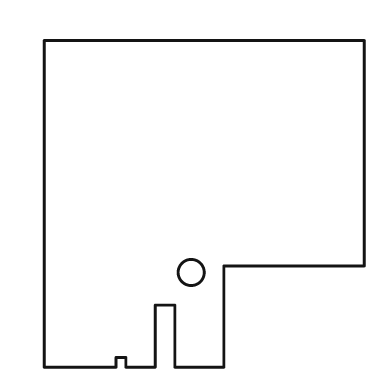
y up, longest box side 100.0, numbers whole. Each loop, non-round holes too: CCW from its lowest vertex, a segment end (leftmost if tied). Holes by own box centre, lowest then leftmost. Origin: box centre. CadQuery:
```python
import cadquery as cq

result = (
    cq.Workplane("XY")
    .moveTo(-49.0, -50.0)
    .lineTo(-27.0, -50.0)
    .lineTo(-27.0, -47.0)
    .lineTo(-24.0, -47.0)
    .lineTo(-24.0, -50.0)
    .lineTo(-15.0, -50.0)
    .lineTo(-15.0, -31.0)
    .lineTo(-9.0, -31.0)
    .lineTo(-9.0, -50.0)
    .lineTo(6.0, -50.0)
    .lineTo(6.0, -19.0)
    .lineTo(49.0, -19.0)
    .lineTo(49.0, 50.0)
    .lineTo(-49.0, 50.0)
    .close()
    .moveTo(-4.0, -21.0)
    .circle(4.0)
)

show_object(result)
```